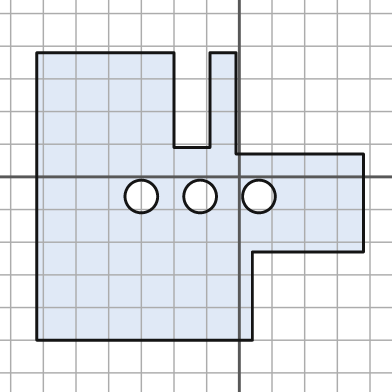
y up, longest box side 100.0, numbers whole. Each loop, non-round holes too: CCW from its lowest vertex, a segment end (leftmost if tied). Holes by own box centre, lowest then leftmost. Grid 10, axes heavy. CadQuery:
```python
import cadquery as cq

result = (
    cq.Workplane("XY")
    .moveTo(-62.0, -50.0)
    .lineTo(4.0, -50.0)
    .lineTo(4.0, -23.0)
    .lineTo(38.0, -23.0)
    .lineTo(38.0, 7.0)
    .lineTo(-1.0, 7.0)
    .lineTo(-1.0, 38.0)
    .lineTo(-9.0, 38.0)
    .lineTo(-9.0, 9.0)
    .lineTo(-20.0, 9.0)
    .lineTo(-20.0, 38.0)
    .lineTo(-62.0, 38.0)
    .close()
    .moveTo(-30.0, -6.0)
    .circle(5.0)
    .moveTo(-12.0, -6.0)
    .circle(5.0)
    .moveTo(6.0, -6.0)
    .circle(5.0)
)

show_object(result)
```